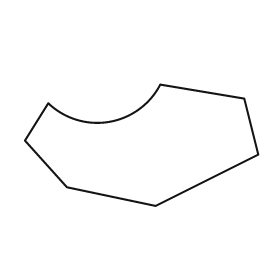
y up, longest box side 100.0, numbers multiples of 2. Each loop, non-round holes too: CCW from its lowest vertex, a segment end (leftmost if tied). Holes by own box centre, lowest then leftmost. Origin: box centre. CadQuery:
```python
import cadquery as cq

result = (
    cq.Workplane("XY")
    .moveTo(6.0, -26.0)
    .lineTo(50.0, -4.0)
    .lineTo(44.0, 20.0)
    .lineTo(8.0, 26.0)
    .threePointArc((-14.0, 10.0), (-40.0, 18.0))
    .lineTo(-50.0, 2.0)
    .lineTo(-32.0, -18.0)
    .close()
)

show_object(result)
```